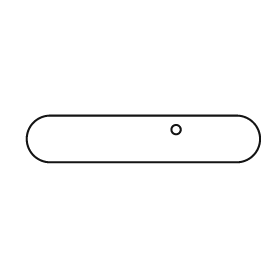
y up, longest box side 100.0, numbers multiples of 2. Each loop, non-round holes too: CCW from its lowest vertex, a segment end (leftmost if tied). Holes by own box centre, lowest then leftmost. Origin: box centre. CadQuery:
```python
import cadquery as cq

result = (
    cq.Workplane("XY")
    .moveTo(-40.0, -10.0)
    .lineTo(40.0, -10.0)
    .threePointArc((50.0, 0.0), (40.0, 10.0))
    .lineTo(-40.0, 10.0)
    .threePointArc((-50.0, 0.0), (-40.0, -10.0))
    .close()
    .moveTo(14.0, 4.0)
    .circle(2.0)
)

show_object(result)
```